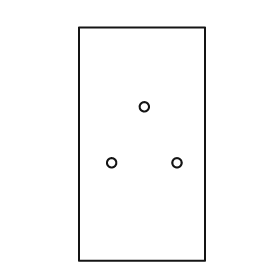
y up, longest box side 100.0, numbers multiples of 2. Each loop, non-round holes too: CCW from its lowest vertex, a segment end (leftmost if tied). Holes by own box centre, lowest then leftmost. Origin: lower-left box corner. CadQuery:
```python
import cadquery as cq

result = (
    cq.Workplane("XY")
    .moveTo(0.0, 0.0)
    .lineTo(54.0, 0.0)
    .lineTo(54.0, 100.0)
    .lineTo(0.0, 100.0)
    .close()
    .moveTo(14.0, 42.0)
    .circle(2.0)
    .moveTo(42.0, 42.0)
    .circle(2.0)
    .moveTo(28.0, 66.0)
    .circle(2.0)
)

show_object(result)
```